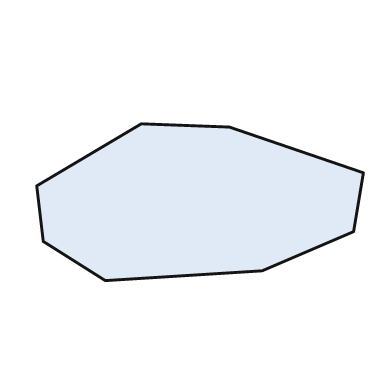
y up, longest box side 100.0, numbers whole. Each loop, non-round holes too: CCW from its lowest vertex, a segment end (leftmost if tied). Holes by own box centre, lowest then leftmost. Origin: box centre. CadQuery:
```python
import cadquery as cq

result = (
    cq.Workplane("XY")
    .moveTo(-29.0, -24.0)
    .lineTo(19.0, -21.0)
    .lineTo(47.0, -9.0)
    .lineTo(50.0, 9.0)
    .lineTo(9.0, 23.0)
    .lineTo(-18.0, 24.0)
    .lineTo(-50.0, 5.0)
    .lineTo(-48.0, -12.0)
    .close()
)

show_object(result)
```